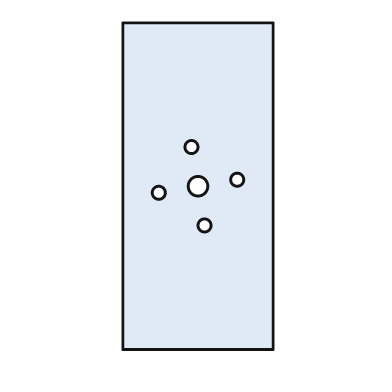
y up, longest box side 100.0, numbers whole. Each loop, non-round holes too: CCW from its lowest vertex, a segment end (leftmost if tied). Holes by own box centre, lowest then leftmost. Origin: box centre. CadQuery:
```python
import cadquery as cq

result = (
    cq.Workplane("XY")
    .moveTo(-23.0, -50.0)
    .lineTo(23.0, -50.0)
    .lineTo(23.0, 50.0)
    .lineTo(-23.0, 50.0)
    .close()
    .moveTo(2.0, -12.0)
    .circle(2.0)
    .moveTo(-12.0, -2.0)
    .circle(2.0)
    .moveTo(0.0, 0.0)
    .circle(3.0)
    .moveTo(12.0, 2.0)
    .circle(2.0)
    .moveTo(-2.0, 12.0)
    .circle(2.0)
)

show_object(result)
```